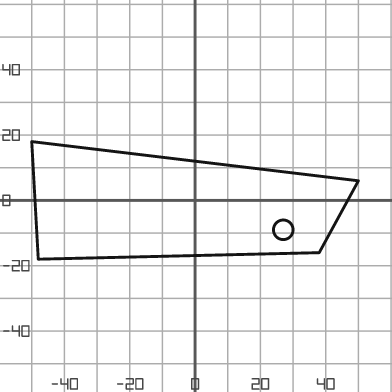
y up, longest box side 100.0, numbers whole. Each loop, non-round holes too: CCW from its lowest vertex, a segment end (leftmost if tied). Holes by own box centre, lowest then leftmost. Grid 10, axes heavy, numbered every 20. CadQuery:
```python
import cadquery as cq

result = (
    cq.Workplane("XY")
    .moveTo(-48.0, -18.0)
    .lineTo(38.0, -16.0)
    .lineTo(50.0, 6.0)
    .lineTo(-50.0, 18.0)
    .close()
    .moveTo(27.0, -9.0)
    .circle(3.0)
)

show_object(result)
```